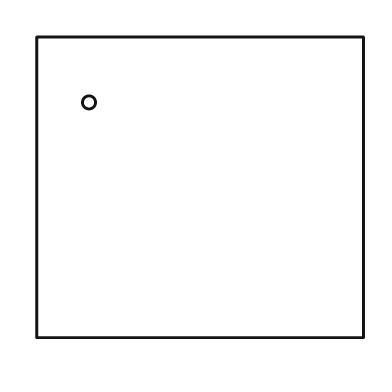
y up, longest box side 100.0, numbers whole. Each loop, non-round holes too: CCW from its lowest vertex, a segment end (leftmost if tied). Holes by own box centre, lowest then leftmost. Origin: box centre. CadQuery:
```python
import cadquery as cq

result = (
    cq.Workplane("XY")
    .moveTo(-50.0, -46.0)
    .lineTo(50.0, -46.0)
    .lineTo(50.0, 46.0)
    .lineTo(-50.0, 46.0)
    .close()
    .moveTo(-34.0, 26.0)
    .circle(2.0)
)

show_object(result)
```